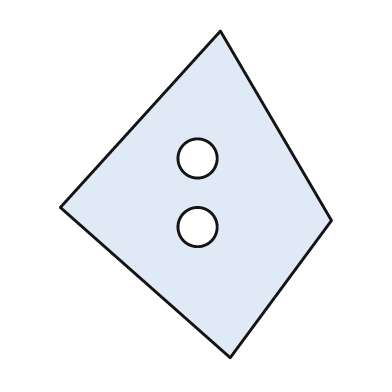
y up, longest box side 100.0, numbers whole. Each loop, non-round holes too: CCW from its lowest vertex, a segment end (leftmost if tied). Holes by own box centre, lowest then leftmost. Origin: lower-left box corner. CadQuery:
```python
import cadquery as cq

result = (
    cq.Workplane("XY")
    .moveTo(52.0, 0.0)
    .lineTo(83.0, 42.0)
    .lineTo(49.0, 100.0)
    .lineTo(0.0, 46.0)
    .close()
    .moveTo(42.0, 40.0)
    .circle(6.0)
    .moveTo(42.0, 61.0)
    .circle(6.0)
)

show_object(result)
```